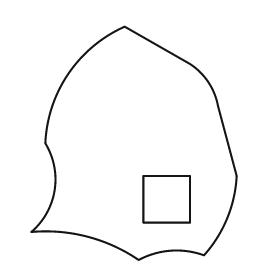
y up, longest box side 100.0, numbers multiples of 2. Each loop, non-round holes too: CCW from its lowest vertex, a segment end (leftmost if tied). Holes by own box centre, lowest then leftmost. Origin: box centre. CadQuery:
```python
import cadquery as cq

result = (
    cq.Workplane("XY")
    .moveTo(2.0, -50.0)
    .threePointArc((16.0, -46.0), (30.0, -48.0))
    .threePointArc((40.0, -32.0), (44.0, -14.0))
    .lineTo(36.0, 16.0)
    .threePointArc((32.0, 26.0), (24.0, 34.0))
    .lineTo(-4.0, 50.0)
    .threePointArc((-28.0, 30.0), (-38.0, 0.0))
    .threePointArc((-34.0, -20.0), (-44.0, -38.0))
    .threePointArc((-20.0, -40.0), (2.0, -50.0))
    .close()
    .moveTo(4.0, -34.0)
    .lineTo(24.0, -34.0)
    .lineTo(24.0, -14.0)
    .lineTo(4.0, -14.0)
    .close()
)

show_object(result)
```